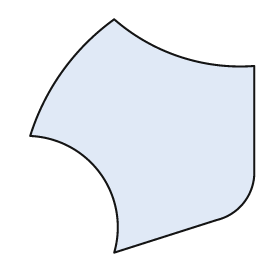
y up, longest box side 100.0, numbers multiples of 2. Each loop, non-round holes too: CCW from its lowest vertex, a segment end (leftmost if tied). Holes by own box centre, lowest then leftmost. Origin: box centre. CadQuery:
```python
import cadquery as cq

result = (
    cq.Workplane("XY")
    .moveTo(-12.0, -50.0)
    .lineTo(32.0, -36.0)
    .threePointArc((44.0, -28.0), (48.0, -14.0))
    .lineTo(48.0, 30.0)
    .threePointArc((16.0, 34.0), (-12.0, 50.0))
    .threePointArc((-34.0, 28.0), (-48.0, 0.0))
    .threePointArc((-18.0, -16.0), (-12.0, -50.0))
    .close()
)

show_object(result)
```